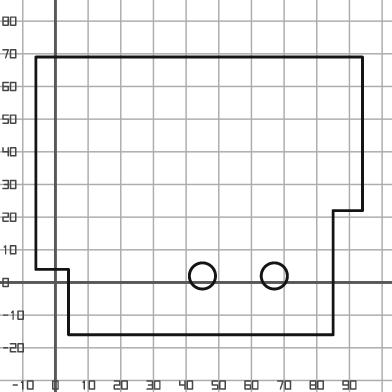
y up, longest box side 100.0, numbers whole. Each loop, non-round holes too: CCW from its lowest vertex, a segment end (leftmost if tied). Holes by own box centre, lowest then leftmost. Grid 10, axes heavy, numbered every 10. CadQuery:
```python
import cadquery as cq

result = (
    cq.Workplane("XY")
    .moveTo(4.0, -16.0)
    .lineTo(85.0, -16.0)
    .lineTo(85.0, 22.0)
    .lineTo(94.0, 22.0)
    .lineTo(94.0, 69.0)
    .lineTo(-6.0, 69.0)
    .lineTo(-6.0, 4.0)
    .lineTo(4.0, 4.0)
    .close()
    .moveTo(45.0, 2.0)
    .circle(4.0)
    .moveTo(67.0, 2.0)
    .circle(4.0)
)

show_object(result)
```